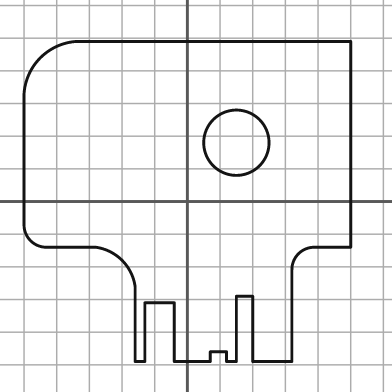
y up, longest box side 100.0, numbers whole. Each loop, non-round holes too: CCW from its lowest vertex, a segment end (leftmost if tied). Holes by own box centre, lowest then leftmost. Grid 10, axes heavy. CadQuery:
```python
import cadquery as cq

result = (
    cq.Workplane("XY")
    .moveTo(-16.0, -49.0)
    .lineTo(-13.0, -49.0)
    .lineTo(-13.0, -31.0)
    .lineTo(-4.0, -31.0)
    .lineTo(-4.0, -49.0)
    .lineTo(7.0, -49.0)
    .lineTo(7.0, -46.0)
    .lineTo(12.0, -46.0)
    .lineTo(12.0, -49.0)
    .lineTo(15.0, -49.0)
    .lineTo(15.0, -29.0)
    .lineTo(20.0, -29.0)
    .lineTo(20.0, -49.0)
    .lineTo(32.0, -49.0)
    .lineTo(32.0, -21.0)
    .threePointArc((34.0, -16.0), (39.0, -14.0))
    .lineTo(50.0, -14.0)
    .lineTo(50.0, 49.0)
    .lineTo(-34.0, 49.0)
    .threePointArc((-45.0, 44.0), (-50.0, 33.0))
    .lineTo(-50.0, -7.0)
    .threePointArc((-48.0, -12.0), (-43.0, -14.0))
    .lineTo(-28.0, -14.0)
    .threePointArc((-20.0, -18.0), (-16.0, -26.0))
    .close()
    .moveTo(15.0, 18.0)
    .circle(10.0)
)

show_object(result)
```